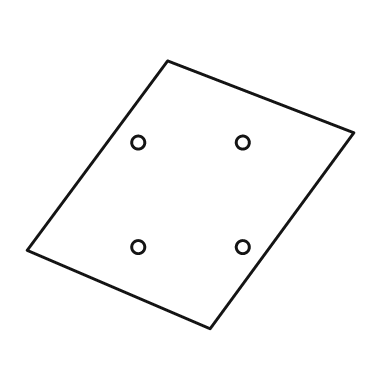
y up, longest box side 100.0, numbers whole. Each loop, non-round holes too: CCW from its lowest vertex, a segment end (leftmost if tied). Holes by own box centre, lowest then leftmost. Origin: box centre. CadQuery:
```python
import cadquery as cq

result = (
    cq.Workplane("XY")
    .moveTo(6.0, -41.0)
    .lineTo(50.0, 19.0)
    .lineTo(-7.0, 41.0)
    .lineTo(-50.0, -17.0)
    .close()
    .moveTo(-16.0, -16.0)
    .circle(2.0)
    .moveTo(16.0, -16.0)
    .circle(2.0)
    .moveTo(-16.0, 16.0)
    .circle(2.0)
    .moveTo(16.0, 16.0)
    .circle(2.0)
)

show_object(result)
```